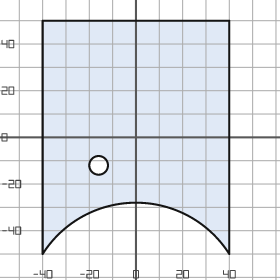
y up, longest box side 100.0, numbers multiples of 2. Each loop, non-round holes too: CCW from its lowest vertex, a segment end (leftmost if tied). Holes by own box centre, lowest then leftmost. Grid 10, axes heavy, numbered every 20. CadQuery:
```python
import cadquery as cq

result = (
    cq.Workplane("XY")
    .moveTo(-40.0, -50.0)
    .threePointArc((0.0, -28.0), (40.0, -50.0))
    .lineTo(40.0, 50.0)
    .lineTo(-40.0, 50.0)
    .close()
    .moveTo(-16.0, -12.0)
    .circle(4.0)
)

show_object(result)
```